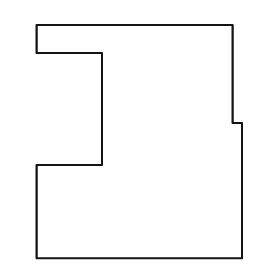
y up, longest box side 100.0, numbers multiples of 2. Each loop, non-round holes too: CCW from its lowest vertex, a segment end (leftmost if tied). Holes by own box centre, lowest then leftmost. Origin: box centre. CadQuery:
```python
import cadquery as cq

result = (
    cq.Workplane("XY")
    .moveTo(-44.0, -50.0)
    .lineTo(44.0, -50.0)
    .lineTo(44.0, 8.0)
    .lineTo(40.0, 8.0)
    .lineTo(40.0, 50.0)
    .lineTo(-44.0, 50.0)
    .lineTo(-44.0, 38.0)
    .lineTo(-16.0, 38.0)
    .lineTo(-16.0, -10.0)
    .lineTo(-44.0, -10.0)
    .close()
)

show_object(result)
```